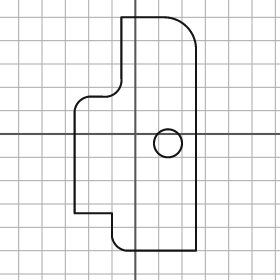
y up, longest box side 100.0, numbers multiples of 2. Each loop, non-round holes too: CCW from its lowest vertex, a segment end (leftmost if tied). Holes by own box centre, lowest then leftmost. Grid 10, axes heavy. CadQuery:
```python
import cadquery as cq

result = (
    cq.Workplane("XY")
    .moveTo(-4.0, -50.0)
    .lineTo(26.0, -50.0)
    .lineTo(26.0, 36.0)
    .threePointArc((22.0, 46.0), (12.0, 50.0))
    .lineTo(-6.0, 50.0)
    .lineTo(-6.0, 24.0)
    .threePointArc((-8.0, 18.0), (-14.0, 16.0))
    .lineTo(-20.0, 16.0)
    .threePointArc((-24.0, 14.0), (-26.0, 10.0))
    .lineTo(-26.0, -34.0)
    .lineTo(-10.0, -34.0)
    .lineTo(-10.0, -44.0)
    .threePointArc((-8.0, -48.0), (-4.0, -50.0))
    .close()
    .moveTo(14.0, -4.0)
    .circle(6.0)
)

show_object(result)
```